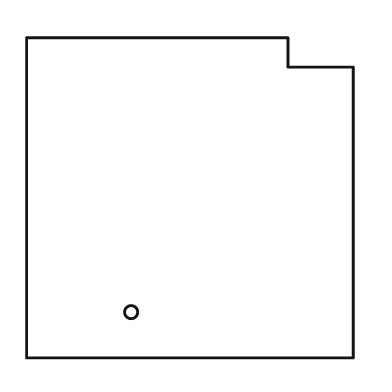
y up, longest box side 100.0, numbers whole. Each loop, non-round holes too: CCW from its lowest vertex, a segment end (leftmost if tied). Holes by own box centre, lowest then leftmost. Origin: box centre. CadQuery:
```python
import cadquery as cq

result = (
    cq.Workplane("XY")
    .moveTo(-50.0, -49.0)
    .lineTo(50.0, -49.0)
    .lineTo(50.0, 40.0)
    .lineTo(30.0, 40.0)
    .lineTo(30.0, 49.0)
    .lineTo(-50.0, 49.0)
    .close()
    .moveTo(-18.0, -35.0)
    .circle(2.0)
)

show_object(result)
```